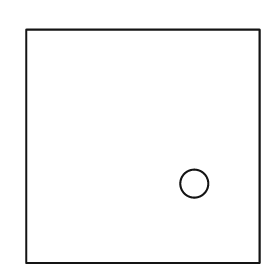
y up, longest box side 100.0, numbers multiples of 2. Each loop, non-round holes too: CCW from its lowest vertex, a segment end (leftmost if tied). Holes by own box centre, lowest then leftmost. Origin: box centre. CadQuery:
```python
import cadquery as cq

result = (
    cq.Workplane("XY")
    .moveTo(-50.0, -50.0)
    .lineTo(50.0, -50.0)
    .lineTo(50.0, 50.0)
    .lineTo(-50.0, 50.0)
    .close()
    .moveTo(22.0, -16.0)
    .circle(6.0)
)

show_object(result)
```